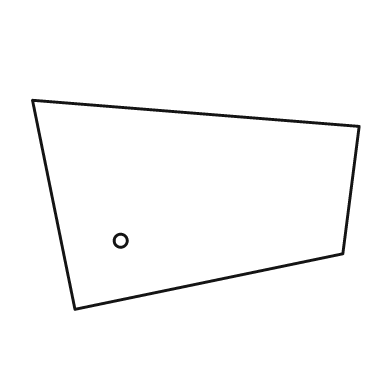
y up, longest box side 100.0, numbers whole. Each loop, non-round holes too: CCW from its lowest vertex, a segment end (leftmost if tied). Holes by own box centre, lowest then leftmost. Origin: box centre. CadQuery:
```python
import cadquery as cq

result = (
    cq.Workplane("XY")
    .moveTo(-37.0, -32.0)
    .lineTo(45.0, -15.0)
    .lineTo(50.0, 24.0)
    .lineTo(-50.0, 32.0)
    .close()
    .moveTo(-23.0, -11.0)
    .circle(2.0)
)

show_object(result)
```